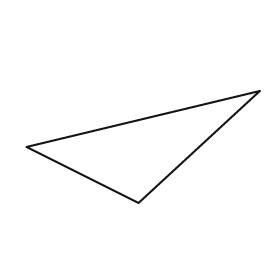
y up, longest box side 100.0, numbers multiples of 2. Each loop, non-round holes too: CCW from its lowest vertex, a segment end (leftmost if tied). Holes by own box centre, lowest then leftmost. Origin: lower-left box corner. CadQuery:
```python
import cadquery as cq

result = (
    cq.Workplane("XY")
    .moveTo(48.0, 0.0)
    .lineTo(100.0, 48.0)
    .lineTo(0.0, 24.0)
    .close()
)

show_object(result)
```